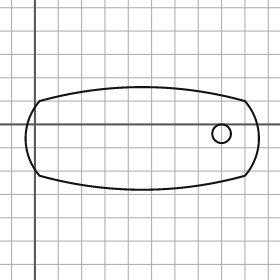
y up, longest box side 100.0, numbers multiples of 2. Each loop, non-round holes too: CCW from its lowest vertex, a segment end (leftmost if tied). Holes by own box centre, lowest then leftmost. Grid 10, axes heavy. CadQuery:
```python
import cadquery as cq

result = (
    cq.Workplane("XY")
    .moveTo(2.0, -22.0)
    .threePointArc((46.0, -28.0), (90.0, -22.0))
    .threePointArc((96.0, -6.0), (90.0, 10.0))
    .threePointArc((46.0, 16.0), (2.0, 10.0))
    .threePointArc((-4.0, -6.0), (2.0, -22.0))
    .close()
    .moveTo(80.0, -4.0)
    .circle(4.0)
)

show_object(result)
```